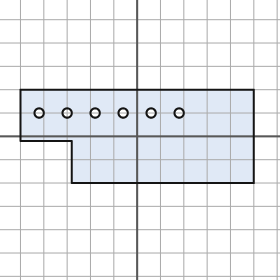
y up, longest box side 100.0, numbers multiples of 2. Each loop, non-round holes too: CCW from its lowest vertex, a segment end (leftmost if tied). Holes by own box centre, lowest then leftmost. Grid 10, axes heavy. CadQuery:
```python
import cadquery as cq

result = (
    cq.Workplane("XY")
    .moveTo(-28.0, -20.0)
    .lineTo(50.0, -20.0)
    .lineTo(50.0, 20.0)
    .lineTo(-50.0, 20.0)
    .lineTo(-50.0, -2.0)
    .lineTo(-28.0, -2.0)
    .close()
    .moveTo(-42.0, 10.0)
    .circle(2.0)
    .moveTo(-30.0, 10.0)
    .circle(2.0)
    .moveTo(-18.0, 10.0)
    .circle(2.0)
    .moveTo(-6.0, 10.0)
    .circle(2.0)
    .moveTo(6.0, 10.0)
    .circle(2.0)
    .moveTo(18.0, 10.0)
    .circle(2.0)
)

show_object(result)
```